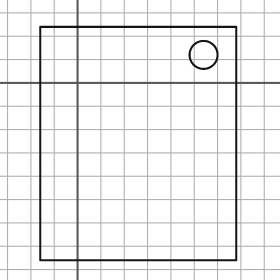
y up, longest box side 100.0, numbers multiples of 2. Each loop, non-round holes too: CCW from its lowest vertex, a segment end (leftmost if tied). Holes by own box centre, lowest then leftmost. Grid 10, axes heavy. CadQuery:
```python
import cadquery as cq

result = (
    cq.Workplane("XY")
    .moveTo(-16.0, -76.0)
    .lineTo(68.0, -76.0)
    .lineTo(68.0, 24.0)
    .lineTo(-16.0, 24.0)
    .close()
    .moveTo(54.0, 12.0)
    .circle(6.0)
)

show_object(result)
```